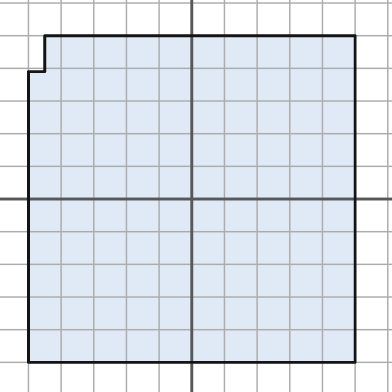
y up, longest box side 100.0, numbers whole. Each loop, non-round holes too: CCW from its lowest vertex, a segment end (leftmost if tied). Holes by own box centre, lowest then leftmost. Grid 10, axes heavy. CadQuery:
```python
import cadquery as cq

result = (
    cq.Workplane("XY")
    .moveTo(-50.0, -50.0)
    .lineTo(50.0, -50.0)
    .lineTo(50.0, 50.0)
    .lineTo(-45.0, 50.0)
    .lineTo(-45.0, 39.0)
    .lineTo(-50.0, 39.0)
    .close()
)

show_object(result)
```